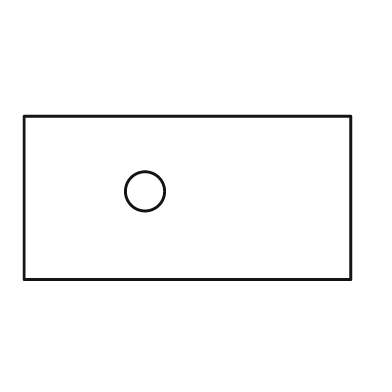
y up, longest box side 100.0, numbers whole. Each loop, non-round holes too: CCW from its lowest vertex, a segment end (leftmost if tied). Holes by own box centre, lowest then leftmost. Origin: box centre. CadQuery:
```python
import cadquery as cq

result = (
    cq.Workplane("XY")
    .moveTo(-50.0, -25.0)
    .lineTo(50.0, -25.0)
    .lineTo(50.0, 25.0)
    .lineTo(-50.0, 25.0)
    .close()
    .moveTo(-13.0, 2.0)
    .circle(6.0)
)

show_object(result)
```